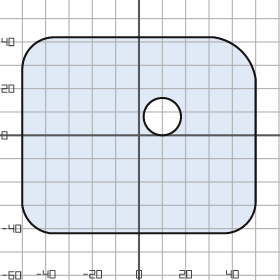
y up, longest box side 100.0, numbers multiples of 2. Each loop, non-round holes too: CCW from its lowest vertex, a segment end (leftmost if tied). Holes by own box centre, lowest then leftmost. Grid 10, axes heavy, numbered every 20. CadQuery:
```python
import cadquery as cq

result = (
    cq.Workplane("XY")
    .moveTo(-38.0, -42.0)
    .lineTo(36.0, -42.0)
    .threePointArc((46.0, -38.0), (50.0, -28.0))
    .lineTo(50.0, 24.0)
    .threePointArc((44.0, 36.0), (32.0, 42.0))
    .lineTo(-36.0, 42.0)
    .threePointArc((-46.0, 38.0), (-50.0, 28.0))
    .lineTo(-50.0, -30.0)
    .threePointArc((-46.0, -38.0), (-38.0, -42.0))
    .close()
    .moveTo(10.0, 8.0)
    .circle(8.0)
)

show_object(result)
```